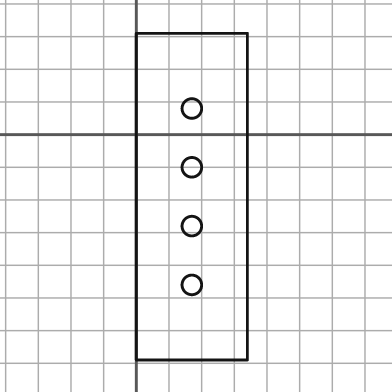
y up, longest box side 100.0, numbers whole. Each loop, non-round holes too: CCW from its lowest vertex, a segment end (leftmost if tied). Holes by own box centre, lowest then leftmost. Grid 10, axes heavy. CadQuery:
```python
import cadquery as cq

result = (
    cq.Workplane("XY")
    .moveTo(0.0, -69.0)
    .lineTo(34.0, -69.0)
    .lineTo(34.0, 31.0)
    .lineTo(0.0, 31.0)
    .close()
    .moveTo(17.0, -46.0)
    .circle(3.0)
    .moveTo(17.0, -28.0)
    .circle(3.0)
    .moveTo(17.0, -10.0)
    .circle(3.0)
    .moveTo(17.0, 8.0)
    .circle(3.0)
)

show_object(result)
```